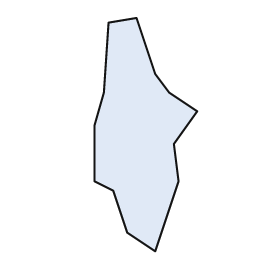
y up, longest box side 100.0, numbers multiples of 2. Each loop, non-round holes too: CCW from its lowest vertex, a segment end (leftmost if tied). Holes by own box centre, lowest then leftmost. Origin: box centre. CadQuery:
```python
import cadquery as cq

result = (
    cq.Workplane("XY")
    .moveTo(4.0, -50.0)
    .lineTo(14.0, -20.0)
    .lineTo(12.0, -4.0)
    .lineTo(22.0, 10.0)
    .lineTo(10.0, 18.0)
    .lineTo(4.0, 26.0)
    .lineTo(-4.0, 50.0)
    .lineTo(-16.0, 48.0)
    .lineTo(-18.0, 18.0)
    .lineTo(-22.0, 4.0)
    .lineTo(-22.0, -20.0)
    .lineTo(-14.0, -24.0)
    .lineTo(-8.0, -42.0)
    .close()
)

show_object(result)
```